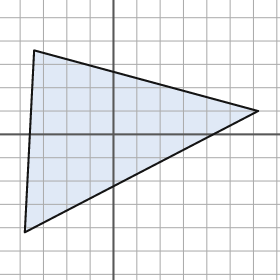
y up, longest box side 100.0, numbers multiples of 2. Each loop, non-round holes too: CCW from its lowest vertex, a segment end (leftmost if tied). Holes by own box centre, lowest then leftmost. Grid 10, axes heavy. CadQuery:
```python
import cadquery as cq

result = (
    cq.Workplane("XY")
    .moveTo(-38.0, -42.0)
    .lineTo(62.0, 10.0)
    .lineTo(-34.0, 36.0)
    .close()
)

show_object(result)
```